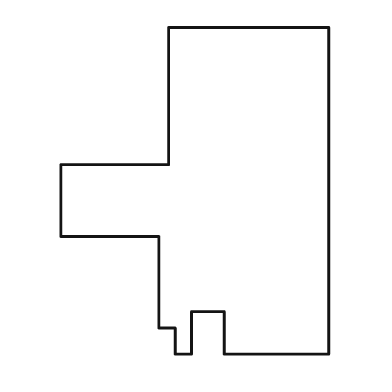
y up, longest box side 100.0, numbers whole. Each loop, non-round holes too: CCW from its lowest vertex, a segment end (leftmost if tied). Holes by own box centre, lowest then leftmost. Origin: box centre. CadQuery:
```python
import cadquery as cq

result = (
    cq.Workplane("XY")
    .moveTo(-6.0, -50.0)
    .lineTo(-1.0, -50.0)
    .lineTo(-1.0, -37.0)
    .lineTo(9.0, -37.0)
    .lineTo(9.0, -50.0)
    .lineTo(41.0, -50.0)
    .lineTo(41.0, 50.0)
    .lineTo(-8.0, 50.0)
    .lineTo(-8.0, 8.0)
    .lineTo(-41.0, 8.0)
    .lineTo(-41.0, -14.0)
    .lineTo(-11.0, -14.0)
    .lineTo(-11.0, -42.0)
    .lineTo(-6.0, -42.0)
    .close()
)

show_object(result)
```